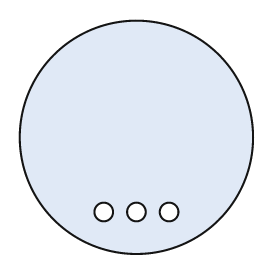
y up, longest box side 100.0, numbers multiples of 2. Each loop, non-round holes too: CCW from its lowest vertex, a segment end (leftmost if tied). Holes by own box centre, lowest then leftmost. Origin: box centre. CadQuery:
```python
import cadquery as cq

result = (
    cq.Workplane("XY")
    .moveTo(0.0, 0.0)
    .circle(50.0)
    .moveTo(-14.0, -32.0)
    .circle(4.0)
    .moveTo(0.0, -32.0)
    .circle(4.0)
    .moveTo(14.0, -32.0)
    .circle(4.0)
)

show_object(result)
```